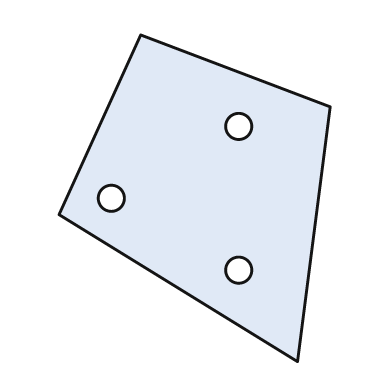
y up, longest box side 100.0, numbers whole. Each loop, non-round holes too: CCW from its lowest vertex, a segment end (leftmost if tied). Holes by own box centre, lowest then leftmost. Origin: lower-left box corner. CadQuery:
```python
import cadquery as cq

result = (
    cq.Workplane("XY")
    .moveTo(73.0, 0.0)
    .lineTo(83.0, 78.0)
    .lineTo(25.0, 100.0)
    .lineTo(0.0, 45.0)
    .close()
    .moveTo(55.0, 28.0)
    .circle(4.0)
    .moveTo(16.0, 50.0)
    .circle(4.0)
    .moveTo(55.0, 72.0)
    .circle(4.0)
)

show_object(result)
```